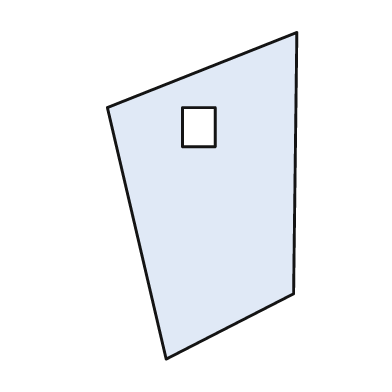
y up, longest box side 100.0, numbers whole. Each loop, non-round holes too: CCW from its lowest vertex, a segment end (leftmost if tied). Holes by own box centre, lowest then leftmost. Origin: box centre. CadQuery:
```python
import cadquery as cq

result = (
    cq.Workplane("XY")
    .moveTo(-11.0, -50.0)
    .lineTo(28.0, -30.0)
    .lineTo(29.0, 50.0)
    .lineTo(-29.0, 27.0)
    .close()
    .moveTo(-6.0, 15.0)
    .lineTo(4.0, 15.0)
    .lineTo(4.0, 27.0)
    .lineTo(-6.0, 27.0)
    .close()
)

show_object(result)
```